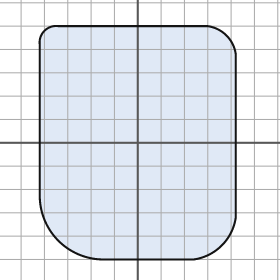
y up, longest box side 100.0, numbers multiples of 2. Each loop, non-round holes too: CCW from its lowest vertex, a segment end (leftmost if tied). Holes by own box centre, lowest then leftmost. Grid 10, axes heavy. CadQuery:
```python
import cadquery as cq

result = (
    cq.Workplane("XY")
    .moveTo(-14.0, -50.0)
    .lineTo(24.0, -50.0)
    .threePointArc((36.0, -44.0), (42.0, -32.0))
    .lineTo(42.0, 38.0)
    .threePointArc((38.0, 46.0), (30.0, 50.0))
    .lineTo(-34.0, 50.0)
    .threePointArc((-40.0, 48.0), (-42.0, 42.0))
    .lineTo(-42.0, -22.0)
    .threePointArc((-34.0, -42.0), (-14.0, -50.0))
    .close()
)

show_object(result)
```